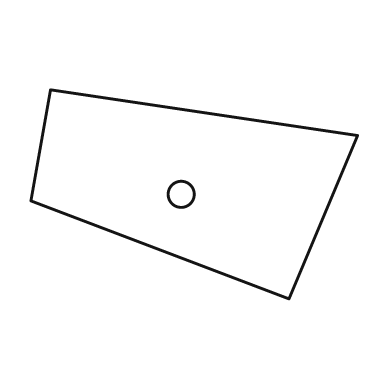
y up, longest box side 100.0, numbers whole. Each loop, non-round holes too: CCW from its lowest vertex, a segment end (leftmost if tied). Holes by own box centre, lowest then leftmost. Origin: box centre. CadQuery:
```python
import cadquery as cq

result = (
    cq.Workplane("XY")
    .moveTo(29.0, -32.0)
    .lineTo(50.0, 18.0)
    .lineTo(-44.0, 32.0)
    .lineTo(-50.0, -2.0)
    .close()
    .moveTo(-4.0, 0.0)
    .circle(4.0)
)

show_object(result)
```